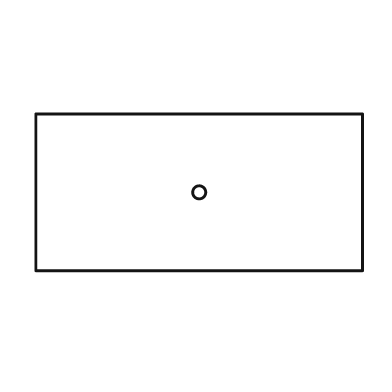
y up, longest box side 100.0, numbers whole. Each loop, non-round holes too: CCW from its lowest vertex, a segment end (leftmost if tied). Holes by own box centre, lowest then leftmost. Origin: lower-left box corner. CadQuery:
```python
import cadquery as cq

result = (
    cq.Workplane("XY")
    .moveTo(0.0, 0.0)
    .lineTo(100.0, 0.0)
    .lineTo(100.0, 48.0)
    .lineTo(0.0, 48.0)
    .close()
    .moveTo(50.0, 24.0)
    .circle(2.0)
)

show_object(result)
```